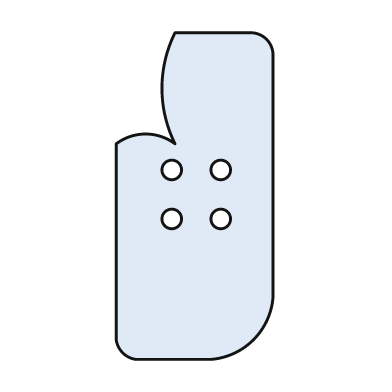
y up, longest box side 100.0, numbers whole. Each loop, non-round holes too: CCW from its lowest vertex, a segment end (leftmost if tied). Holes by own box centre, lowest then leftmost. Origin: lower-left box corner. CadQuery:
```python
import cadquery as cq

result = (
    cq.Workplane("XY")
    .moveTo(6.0, 0.0)
    .lineTo(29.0, 0.0)
    .threePointArc((42.0, 6.0), (48.0, 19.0))
    .lineTo(48.0, 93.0)
    .threePointArc((46.0, 98.0), (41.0, 100.0))
    .lineTo(18.0, 100.0)
    .threePointArc((14.0, 83.0), (18.0, 66.0))
    .threePointArc((9.0, 69.0), (0.0, 66.0))
    .lineTo(0.0, 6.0)
    .threePointArc((2.0, 2.0), (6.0, 0.0))
    .close()
    .moveTo(17.0, 43.0)
    .circle(3.0)
    .moveTo(32.0, 43.0)
    .circle(3.0)
    .moveTo(17.0, 58.0)
    .circle(3.0)
    .moveTo(32.0, 58.0)
    .circle(3.0)
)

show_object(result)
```